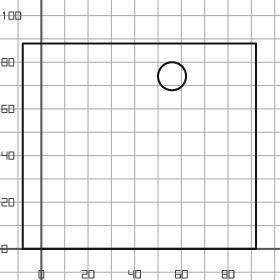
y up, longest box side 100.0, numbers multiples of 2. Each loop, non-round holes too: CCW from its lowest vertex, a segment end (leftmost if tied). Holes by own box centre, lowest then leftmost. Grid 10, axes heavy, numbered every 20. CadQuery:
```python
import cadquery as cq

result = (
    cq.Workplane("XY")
    .moveTo(-8.0, 0.0)
    .lineTo(92.0, 0.0)
    .lineTo(92.0, 88.0)
    .lineTo(-8.0, 88.0)
    .close()
    .moveTo(56.0, 74.0)
    .circle(6.0)
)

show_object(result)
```